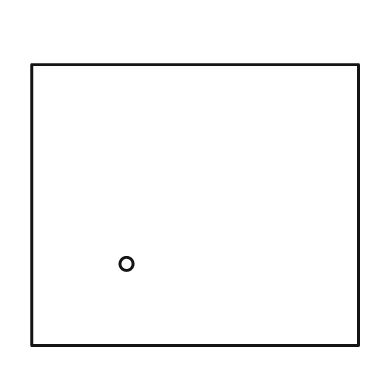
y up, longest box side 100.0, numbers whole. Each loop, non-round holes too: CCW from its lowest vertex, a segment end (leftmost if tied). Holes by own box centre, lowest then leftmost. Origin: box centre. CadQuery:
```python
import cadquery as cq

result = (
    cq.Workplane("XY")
    .moveTo(-50.0, -43.0)
    .lineTo(50.0, -43.0)
    .lineTo(50.0, 43.0)
    .lineTo(-50.0, 43.0)
    .close()
    .moveTo(-21.0, -18.0)
    .circle(2.0)
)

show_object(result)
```